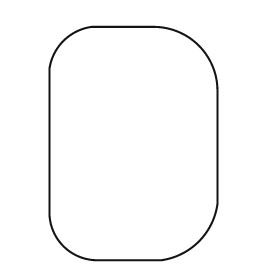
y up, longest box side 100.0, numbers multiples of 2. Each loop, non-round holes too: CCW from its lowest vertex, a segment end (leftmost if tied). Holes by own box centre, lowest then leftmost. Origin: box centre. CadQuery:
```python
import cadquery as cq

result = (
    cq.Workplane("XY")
    .moveTo(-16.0, -50.0)
    .lineTo(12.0, -50.0)
    .threePointArc((28.0, -42.0), (36.0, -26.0))
    .lineTo(36.0, 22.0)
    .threePointArc((28.0, 42.0), (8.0, 50.0))
    .lineTo(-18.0, 50.0)
    .threePointArc((-30.0, 44.0), (-36.0, 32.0))
    .lineTo(-36.0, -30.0)
    .threePointArc((-30.0, -44.0), (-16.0, -50.0))
    .close()
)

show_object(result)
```